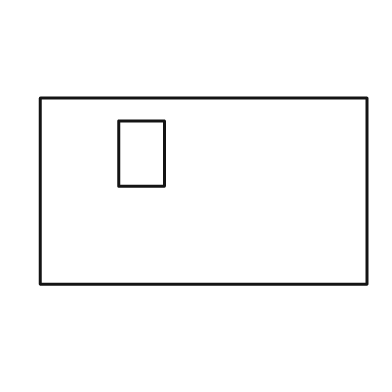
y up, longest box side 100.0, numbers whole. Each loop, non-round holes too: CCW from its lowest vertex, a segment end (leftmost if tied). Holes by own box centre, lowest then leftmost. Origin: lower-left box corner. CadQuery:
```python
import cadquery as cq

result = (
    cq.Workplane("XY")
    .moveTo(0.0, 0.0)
    .lineTo(100.0, 0.0)
    .lineTo(100.0, 57.0)
    .lineTo(0.0, 57.0)
    .close()
    .moveTo(24.0, 30.0)
    .lineTo(38.0, 30.0)
    .lineTo(38.0, 50.0)
    .lineTo(24.0, 50.0)
    .close()
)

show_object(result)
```